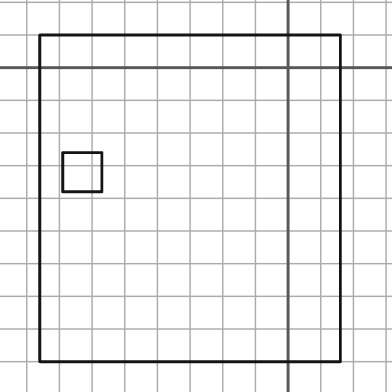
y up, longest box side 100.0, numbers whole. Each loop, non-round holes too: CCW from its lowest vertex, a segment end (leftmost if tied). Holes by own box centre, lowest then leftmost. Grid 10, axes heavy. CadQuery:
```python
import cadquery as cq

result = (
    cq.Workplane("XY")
    .moveTo(-76.0, -90.0)
    .lineTo(16.0, -90.0)
    .lineTo(16.0, 10.0)
    .lineTo(-76.0, 10.0)
    .close()
    .moveTo(-69.0, -38.0)
    .lineTo(-57.0, -38.0)
    .lineTo(-57.0, -26.0)
    .lineTo(-69.0, -26.0)
    .close()
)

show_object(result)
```